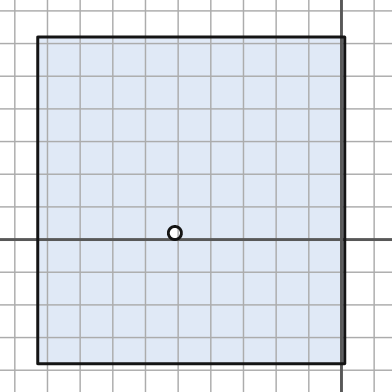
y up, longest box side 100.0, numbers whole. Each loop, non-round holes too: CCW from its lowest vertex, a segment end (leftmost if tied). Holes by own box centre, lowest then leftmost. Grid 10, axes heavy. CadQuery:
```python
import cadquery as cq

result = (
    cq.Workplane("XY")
    .moveTo(-93.0, -38.0)
    .lineTo(1.0, -38.0)
    .lineTo(1.0, 62.0)
    .lineTo(-93.0, 62.0)
    .close()
    .moveTo(-51.0, 2.0)
    .circle(2.0)
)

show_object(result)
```